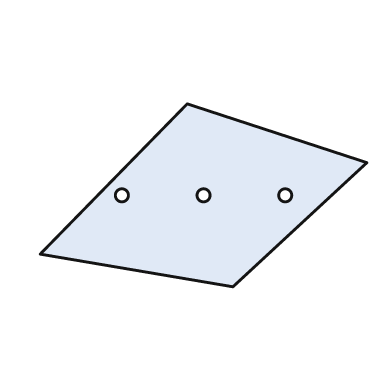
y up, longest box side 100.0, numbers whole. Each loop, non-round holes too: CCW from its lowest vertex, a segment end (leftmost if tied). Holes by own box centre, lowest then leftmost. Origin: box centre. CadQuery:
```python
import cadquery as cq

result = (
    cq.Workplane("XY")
    .moveTo(9.0, -28.0)
    .lineTo(50.0, 10.0)
    .lineTo(-5.0, 28.0)
    .lineTo(-50.0, -18.0)
    .close()
    .moveTo(-25.0, 0.0)
    .circle(2.0)
    .moveTo(0.0, 0.0)
    .circle(2.0)
    .moveTo(25.0, 0.0)
    .circle(2.0)
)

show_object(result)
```